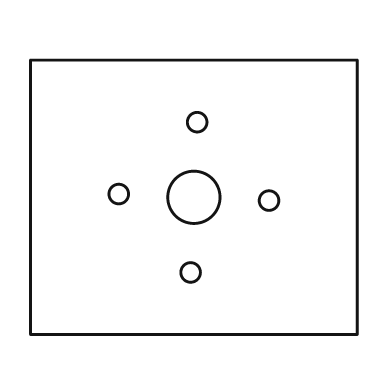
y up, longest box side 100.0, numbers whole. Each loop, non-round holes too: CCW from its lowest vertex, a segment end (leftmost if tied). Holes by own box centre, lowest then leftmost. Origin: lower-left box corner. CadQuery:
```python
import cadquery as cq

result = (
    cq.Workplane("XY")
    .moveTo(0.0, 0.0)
    .lineTo(100.0, 0.0)
    .lineTo(100.0, 84.0)
    .lineTo(0.0, 84.0)
    .close()
    .moveTo(49.0, 19.0)
    .circle(3.0)
    .moveTo(73.0, 41.0)
    .circle(3.0)
    .moveTo(50.0, 42.0)
    .circle(8.0)
    .moveTo(27.0, 43.0)
    .circle(3.0)
    .moveTo(51.0, 65.0)
    .circle(3.0)
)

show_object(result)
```